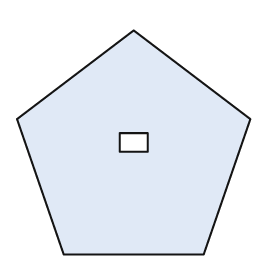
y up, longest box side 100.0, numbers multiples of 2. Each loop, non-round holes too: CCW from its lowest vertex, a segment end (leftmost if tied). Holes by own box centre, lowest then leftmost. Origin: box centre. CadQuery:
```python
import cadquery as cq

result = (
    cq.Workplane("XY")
    .moveTo(-30.0, -48.0)
    .lineTo(30.0, -48.0)
    .lineTo(50.0, 10.0)
    .lineTo(0.0, 48.0)
    .lineTo(-50.0, 10.0)
    .close()
    .moveTo(-6.0, -4.0)
    .lineTo(6.0, -4.0)
    .lineTo(6.0, 4.0)
    .lineTo(-6.0, 4.0)
    .close()
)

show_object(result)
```